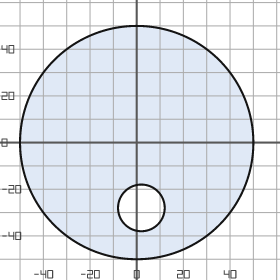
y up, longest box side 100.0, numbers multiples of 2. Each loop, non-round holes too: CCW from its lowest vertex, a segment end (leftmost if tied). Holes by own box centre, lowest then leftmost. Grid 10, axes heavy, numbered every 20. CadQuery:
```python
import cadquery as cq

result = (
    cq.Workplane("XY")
    .moveTo(0.0, 0.0)
    .circle(50.0)
    .moveTo(2.0, -28.0)
    .circle(10.0)
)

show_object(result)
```